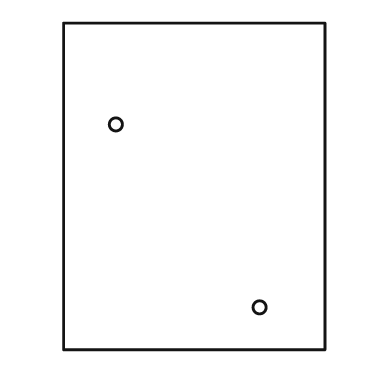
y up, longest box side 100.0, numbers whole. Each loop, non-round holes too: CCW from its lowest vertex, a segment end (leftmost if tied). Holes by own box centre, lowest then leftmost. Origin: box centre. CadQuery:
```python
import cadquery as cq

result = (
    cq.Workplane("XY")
    .moveTo(-40.0, -50.0)
    .lineTo(40.0, -50.0)
    .lineTo(40.0, 50.0)
    .lineTo(-40.0, 50.0)
    .close()
    .moveTo(20.0, -37.0)
    .circle(2.0)
    .moveTo(-24.0, 19.0)
    .circle(2.0)
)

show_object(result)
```